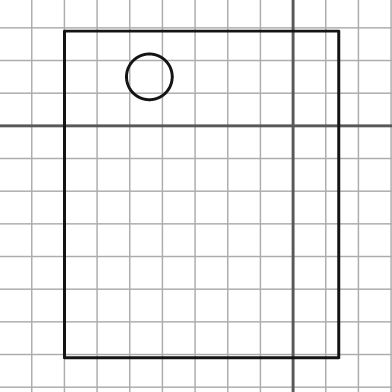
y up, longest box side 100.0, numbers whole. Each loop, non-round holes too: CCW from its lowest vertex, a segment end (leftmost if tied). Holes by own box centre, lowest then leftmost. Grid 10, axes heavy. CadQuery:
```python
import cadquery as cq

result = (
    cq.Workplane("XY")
    .moveTo(-70.0, -71.0)
    .lineTo(14.0, -71.0)
    .lineTo(14.0, 29.0)
    .lineTo(-70.0, 29.0)
    .close()
    .moveTo(-44.0, 15.0)
    .circle(7.0)
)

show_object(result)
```